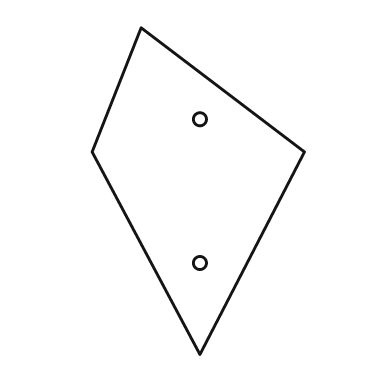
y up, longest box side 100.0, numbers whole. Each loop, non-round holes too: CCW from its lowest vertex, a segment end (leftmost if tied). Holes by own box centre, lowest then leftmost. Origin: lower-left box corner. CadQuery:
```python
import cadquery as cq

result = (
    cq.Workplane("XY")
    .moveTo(33.0, 0.0)
    .lineTo(65.0, 62.0)
    .lineTo(15.0, 100.0)
    .lineTo(0.0, 62.0)
    .close()
    .moveTo(33.0, 28.0)
    .circle(2.0)
    .moveTo(33.0, 72.0)
    .circle(2.0)
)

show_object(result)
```